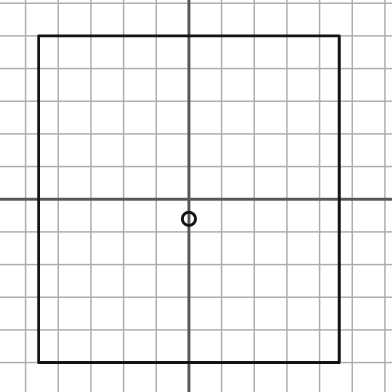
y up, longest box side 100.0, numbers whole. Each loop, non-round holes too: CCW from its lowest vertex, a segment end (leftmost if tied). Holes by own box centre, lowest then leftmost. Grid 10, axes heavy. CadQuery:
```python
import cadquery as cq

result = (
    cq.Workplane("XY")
    .moveTo(-46.0, -50.0)
    .lineTo(46.0, -50.0)
    .lineTo(46.0, 50.0)
    .lineTo(-46.0, 50.0)
    .close()
    .moveTo(0.0, -6.0)
    .circle(2.0)
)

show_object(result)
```